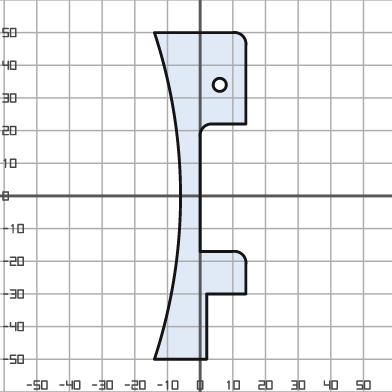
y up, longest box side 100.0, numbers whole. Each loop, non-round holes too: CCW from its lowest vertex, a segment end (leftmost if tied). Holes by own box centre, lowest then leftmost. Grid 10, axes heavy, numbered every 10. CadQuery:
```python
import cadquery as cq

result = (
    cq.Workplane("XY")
    .moveTo(-14.0, -50.0)
    .lineTo(2.0, -50.0)
    .lineTo(2.0, -30.0)
    .lineTo(14.0, -30.0)
    .lineTo(14.0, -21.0)
    .threePointArc((13.0, -18.0), (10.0, -17.0))
    .lineTo(0.0, -17.0)
    .lineTo(0.0, 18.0)
    .threePointArc((1.0, 21.0), (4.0, 22.0))
    .lineTo(14.0, 22.0)
    .lineTo(14.0, 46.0)
    .threePointArc((13.0, 49.0), (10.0, 50.0))
    .lineTo(-14.0, 50.0)
    .threePointArc((-6.0, 0.0), (-14.0, -50.0))
    .close()
    .moveTo(6.0, 34.0)
    .circle(2.0)
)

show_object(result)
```